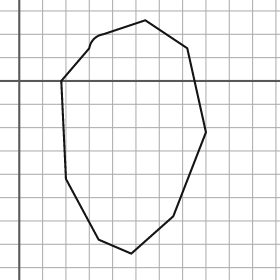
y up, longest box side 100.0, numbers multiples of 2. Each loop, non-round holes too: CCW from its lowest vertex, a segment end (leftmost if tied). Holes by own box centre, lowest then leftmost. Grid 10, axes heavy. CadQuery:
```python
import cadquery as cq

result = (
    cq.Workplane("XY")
    .moveTo(48.0, -74.0)
    .lineTo(66.0, -58.0)
    .lineTo(80.0, -22.0)
    .lineTo(72.0, 14.0)
    .lineTo(54.0, 26.0)
    .lineTo(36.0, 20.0)
    .threePointArc((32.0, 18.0), (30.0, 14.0))
    .lineTo(18.0, 0.0)
    .lineTo(20.0, -42.0)
    .lineTo(34.0, -68.0)
    .close()
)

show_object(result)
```